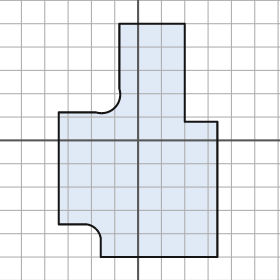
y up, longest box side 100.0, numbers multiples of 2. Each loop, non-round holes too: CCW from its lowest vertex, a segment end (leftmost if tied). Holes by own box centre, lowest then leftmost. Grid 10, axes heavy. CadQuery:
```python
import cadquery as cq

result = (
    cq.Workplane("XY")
    .moveTo(-16.0, -50.0)
    .lineTo(34.0, -50.0)
    .lineTo(34.0, 8.0)
    .lineTo(20.0, 8.0)
    .lineTo(20.0, 50.0)
    .lineTo(-8.0, 50.0)
    .lineTo(-8.0, 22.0)
    .threePointArc((-10.0, 14.0), (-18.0, 12.0))
    .lineTo(-34.0, 12.0)
    .lineTo(-34.0, -36.0)
    .lineTo(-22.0, -36.0)
    .threePointArc((-18.0, -38.0), (-16.0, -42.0))
    .close()
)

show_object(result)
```